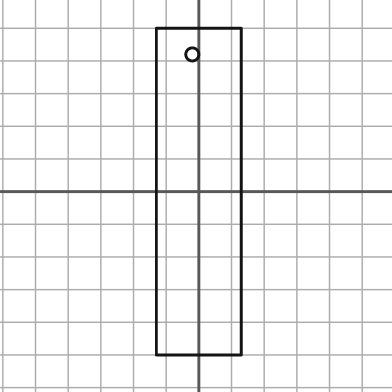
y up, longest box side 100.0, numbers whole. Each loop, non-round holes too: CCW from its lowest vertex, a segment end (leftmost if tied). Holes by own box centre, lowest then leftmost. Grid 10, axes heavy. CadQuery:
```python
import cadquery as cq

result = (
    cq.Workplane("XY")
    .moveTo(-13.0, -50.0)
    .lineTo(13.0, -50.0)
    .lineTo(13.0, 50.0)
    .lineTo(-13.0, 50.0)
    .close()
    .moveTo(-2.0, 42.0)
    .circle(2.0)
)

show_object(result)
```